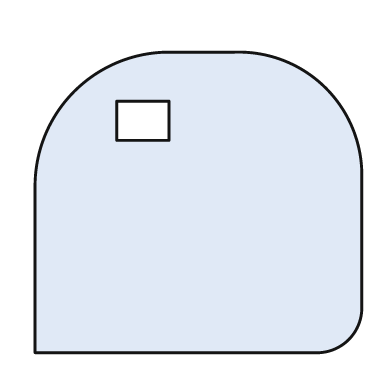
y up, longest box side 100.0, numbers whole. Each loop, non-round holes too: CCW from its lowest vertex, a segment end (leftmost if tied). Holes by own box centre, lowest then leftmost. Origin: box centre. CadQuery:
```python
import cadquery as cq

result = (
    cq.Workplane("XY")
    .moveTo(-50.0, -46.0)
    .lineTo(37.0, -46.0)
    .threePointArc((46.0, -42.0), (50.0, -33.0))
    .lineTo(50.0, 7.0)
    .threePointArc((39.0, 35.0), (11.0, 46.0))
    .lineTo(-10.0, 46.0)
    .threePointArc((-38.0, 34.0), (-50.0, 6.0))
    .close()
    .moveTo(-25.0, 19.0)
    .lineTo(-9.0, 19.0)
    .lineTo(-9.0, 31.0)
    .lineTo(-25.0, 31.0)
    .close()
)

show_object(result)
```